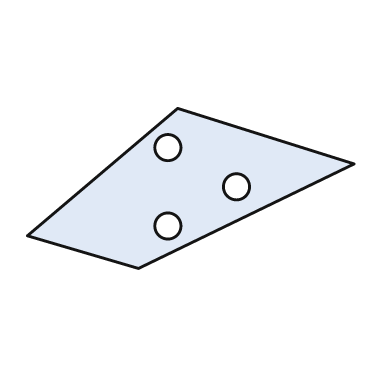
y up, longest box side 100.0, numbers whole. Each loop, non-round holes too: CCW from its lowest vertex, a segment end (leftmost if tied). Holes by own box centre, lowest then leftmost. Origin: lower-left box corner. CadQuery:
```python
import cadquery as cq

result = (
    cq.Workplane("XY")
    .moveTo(34.0, 0.0)
    .lineTo(100.0, 32.0)
    .lineTo(46.0, 49.0)
    .lineTo(0.0, 10.0)
    .close()
    .moveTo(43.0, 13.0)
    .circle(4.0)
    .moveTo(64.0, 25.0)
    .circle(4.0)
    .moveTo(43.0, 37.0)
    .circle(4.0)
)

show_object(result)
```